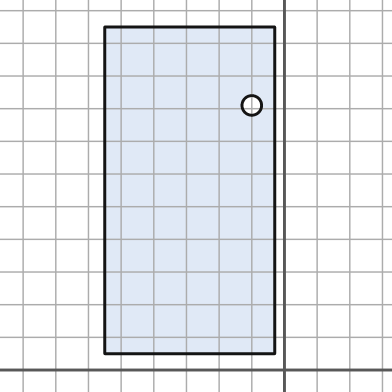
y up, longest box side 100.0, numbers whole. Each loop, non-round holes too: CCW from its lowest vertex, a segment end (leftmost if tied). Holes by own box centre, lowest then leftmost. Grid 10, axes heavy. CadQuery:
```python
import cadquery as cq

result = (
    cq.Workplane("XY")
    .moveTo(-55.0, 5.0)
    .lineTo(-3.0, 5.0)
    .lineTo(-3.0, 105.0)
    .lineTo(-55.0, 105.0)
    .close()
    .moveTo(-10.0, 81.0)
    .circle(3.0)
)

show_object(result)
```